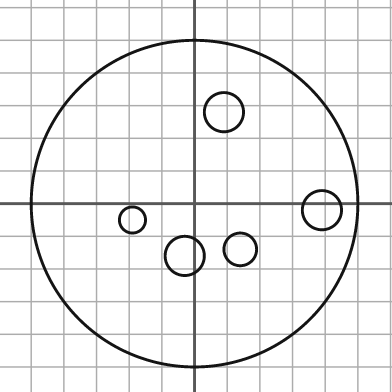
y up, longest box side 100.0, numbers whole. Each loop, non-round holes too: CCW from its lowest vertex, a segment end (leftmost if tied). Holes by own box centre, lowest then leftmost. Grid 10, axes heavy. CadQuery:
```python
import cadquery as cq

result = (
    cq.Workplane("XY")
    .moveTo(0.0, 0.0)
    .circle(50.0)
    .moveTo(-3.0, -16.0)
    .circle(6.0)
    .moveTo(14.0, -14.0)
    .circle(5.0)
    .moveTo(-19.0, -5.0)
    .circle(4.0)
    .moveTo(39.0, -2.0)
    .circle(6.0)
    .moveTo(9.0, 28.0)
    .circle(6.0)
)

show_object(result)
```